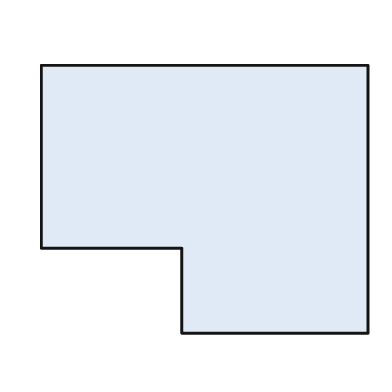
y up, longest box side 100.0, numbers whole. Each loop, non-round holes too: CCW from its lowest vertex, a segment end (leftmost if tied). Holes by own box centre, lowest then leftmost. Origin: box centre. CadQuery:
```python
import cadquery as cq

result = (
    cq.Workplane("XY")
    .moveTo(-7.0, -41.0)
    .lineTo(50.0, -41.0)
    .lineTo(50.0, 41.0)
    .lineTo(-50.0, 41.0)
    .lineTo(-50.0, -15.0)
    .lineTo(-7.0, -15.0)
    .close()
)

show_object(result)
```